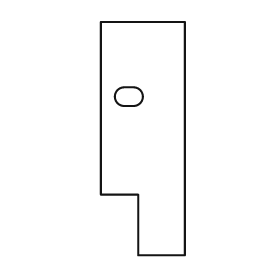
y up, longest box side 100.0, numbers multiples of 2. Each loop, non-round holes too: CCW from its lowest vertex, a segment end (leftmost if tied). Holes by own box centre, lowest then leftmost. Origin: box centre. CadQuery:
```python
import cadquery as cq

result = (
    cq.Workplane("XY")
    .moveTo(-2.0, -50.0)
    .lineTo(18.0, -50.0)
    .lineTo(18.0, 50.0)
    .lineTo(-18.0, 50.0)
    .lineTo(-18.0, -24.0)
    .lineTo(-2.0, -24.0)
    .close()
    .moveTo(-8.0, 14.0)
    .lineTo(-4.0, 14.0)
    .threePointArc((0.0, 18.0), (-4.0, 22.0))
    .lineTo(-8.0, 22.0)
    .threePointArc((-12.0, 18.0), (-8.0, 14.0))
    .close()
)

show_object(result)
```